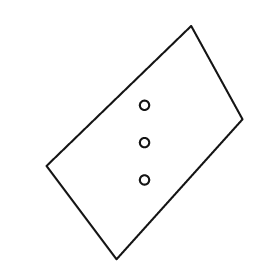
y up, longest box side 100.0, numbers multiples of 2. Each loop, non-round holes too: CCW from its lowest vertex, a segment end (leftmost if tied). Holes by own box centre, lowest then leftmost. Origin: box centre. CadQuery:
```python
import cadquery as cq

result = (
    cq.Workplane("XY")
    .moveTo(-12.0, -50.0)
    .lineTo(42.0, 10.0)
    .lineTo(20.0, 50.0)
    .lineTo(-42.0, -10.0)
    .close()
    .moveTo(0.0, -16.0)
    .circle(2.0)
    .moveTo(0.0, 0.0)
    .circle(2.0)
    .moveTo(0.0, 16.0)
    .circle(2.0)
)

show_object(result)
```